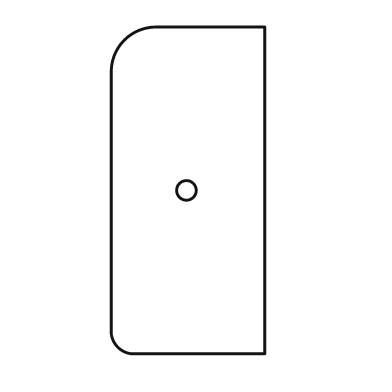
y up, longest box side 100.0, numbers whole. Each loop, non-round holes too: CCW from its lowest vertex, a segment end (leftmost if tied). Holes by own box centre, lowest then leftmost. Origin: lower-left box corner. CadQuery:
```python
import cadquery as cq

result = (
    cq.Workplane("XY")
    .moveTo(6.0, 0.0)
    .lineTo(47.0, 0.0)
    .lineTo(47.0, 100.0)
    .lineTo(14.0, 100.0)
    .threePointArc((4.0, 96.0), (0.0, 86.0))
    .lineTo(0.0, 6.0)
    .threePointArc((2.0, 2.0), (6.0, 0.0))
    .close()
    .moveTo(23.0, 50.0)
    .circle(3.0)
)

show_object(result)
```